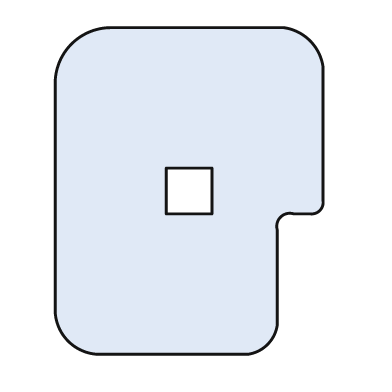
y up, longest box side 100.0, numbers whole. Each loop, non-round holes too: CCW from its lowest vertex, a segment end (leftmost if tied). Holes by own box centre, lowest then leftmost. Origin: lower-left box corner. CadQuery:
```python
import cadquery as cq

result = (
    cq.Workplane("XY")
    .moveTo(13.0, 0.0)
    .lineTo(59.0, 0.0)
    .threePointArc((65.0, 3.0), (68.0, 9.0))
    .lineTo(68.0, 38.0)
    .threePointArc((69.0, 42.0), (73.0, 43.0))
    .lineTo(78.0, 43.0)
    .threePointArc((81.0, 44.0), (82.0, 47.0))
    .lineTo(82.0, 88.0)
    .threePointArc((78.0, 96.0), (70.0, 100.0))
    .lineTo(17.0, 100.0)
    .threePointArc((5.0, 95.0), (0.0, 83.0))
    .lineTo(0.0, 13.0)
    .threePointArc((4.0, 4.0), (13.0, 0.0))
    .close()
    .moveTo(34.0, 43.0)
    .lineTo(48.0, 43.0)
    .lineTo(48.0, 57.0)
    .lineTo(34.0, 57.0)
    .close()
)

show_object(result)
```